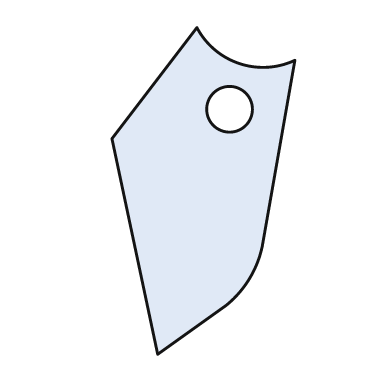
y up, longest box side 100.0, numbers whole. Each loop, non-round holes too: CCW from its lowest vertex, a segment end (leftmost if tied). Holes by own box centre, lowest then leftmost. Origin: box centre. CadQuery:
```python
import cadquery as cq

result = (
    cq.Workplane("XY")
    .moveTo(-14.0, -50.0)
    .lineTo(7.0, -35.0)
    .threePointArc((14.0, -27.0), (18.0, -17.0))
    .lineTo(28.0, 40.0)
    .threePointArc((11.0, 39.0), (-2.0, 50.0))
    .lineTo(-28.0, 16.0)
    .close()
    .moveTo(8.0, 25.0)
    .circle(7.0)
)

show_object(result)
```